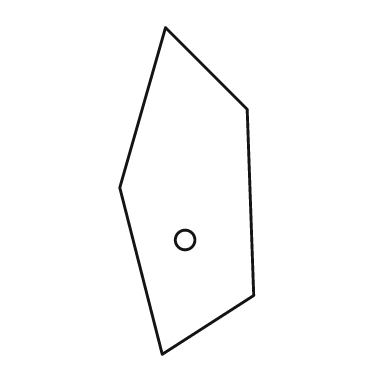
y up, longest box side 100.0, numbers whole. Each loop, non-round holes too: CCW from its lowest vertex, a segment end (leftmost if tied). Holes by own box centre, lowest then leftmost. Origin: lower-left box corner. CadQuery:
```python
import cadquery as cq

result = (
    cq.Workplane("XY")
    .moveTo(13.0, 0.0)
    .lineTo(41.0, 18.0)
    .lineTo(39.0, 75.0)
    .lineTo(14.0, 100.0)
    .lineTo(0.0, 51.0)
    .close()
    .moveTo(20.0, 35.0)
    .circle(3.0)
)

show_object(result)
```